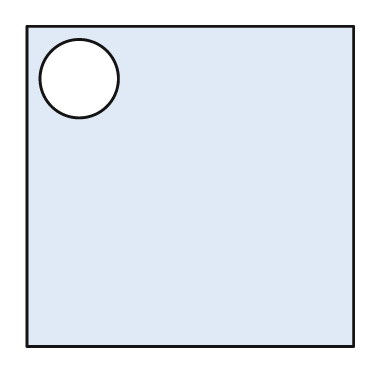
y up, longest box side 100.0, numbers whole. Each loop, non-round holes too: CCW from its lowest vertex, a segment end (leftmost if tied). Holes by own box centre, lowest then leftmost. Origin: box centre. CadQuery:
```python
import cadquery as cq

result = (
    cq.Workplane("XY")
    .moveTo(-50.0, -49.0)
    .lineTo(50.0, -49.0)
    .lineTo(50.0, 49.0)
    .lineTo(-50.0, 49.0)
    .close()
    .moveTo(-34.0, 33.0)
    .circle(12.0)
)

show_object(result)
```